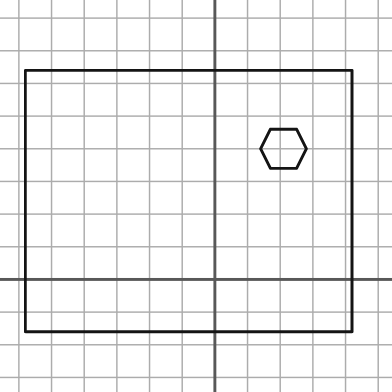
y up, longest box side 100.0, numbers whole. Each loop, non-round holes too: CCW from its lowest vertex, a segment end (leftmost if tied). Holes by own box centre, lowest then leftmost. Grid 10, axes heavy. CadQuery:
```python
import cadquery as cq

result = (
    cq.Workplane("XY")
    .moveTo(-58.0, -16.0)
    .lineTo(42.0, -16.0)
    .lineTo(42.0, 64.0)
    .lineTo(-58.0, 64.0)
    .close()
    .moveTo(17.0, 34.0)
    .lineTo(25.0, 34.0)
    .lineTo(28.0, 40.0)
    .lineTo(25.0, 46.0)
    .lineTo(17.0, 46.0)
    .lineTo(14.0, 40.0)
    .close()
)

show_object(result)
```